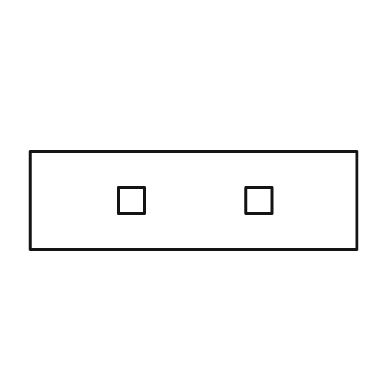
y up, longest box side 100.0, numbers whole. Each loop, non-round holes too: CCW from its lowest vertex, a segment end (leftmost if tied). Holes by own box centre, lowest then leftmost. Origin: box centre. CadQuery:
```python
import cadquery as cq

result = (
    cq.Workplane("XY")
    .moveTo(-50.0, -15.0)
    .lineTo(50.0, -15.0)
    .lineTo(50.0, 15.0)
    .lineTo(-50.0, 15.0)
    .close()
    .moveTo(-23.0, -4.0)
    .lineTo(-15.0, -4.0)
    .lineTo(-15.0, 4.0)
    .lineTo(-23.0, 4.0)
    .close()
    .moveTo(16.0, -4.0)
    .lineTo(24.0, -4.0)
    .lineTo(24.0, 4.0)
    .lineTo(16.0, 4.0)
    .close()
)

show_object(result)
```